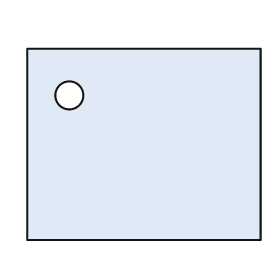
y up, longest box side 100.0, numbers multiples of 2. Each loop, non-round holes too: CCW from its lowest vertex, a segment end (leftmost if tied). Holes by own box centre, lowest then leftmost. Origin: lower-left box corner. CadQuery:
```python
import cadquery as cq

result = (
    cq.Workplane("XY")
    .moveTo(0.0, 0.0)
    .lineTo(100.0, 0.0)
    .lineTo(100.0, 82.0)
    .lineTo(0.0, 82.0)
    .close()
    .moveTo(18.0, 62.0)
    .circle(6.0)
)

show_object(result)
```